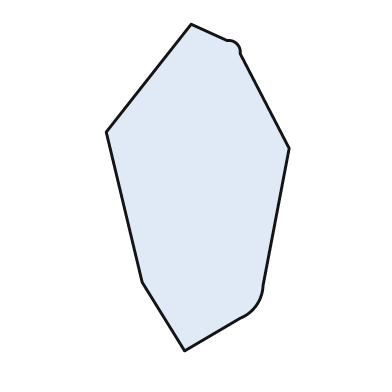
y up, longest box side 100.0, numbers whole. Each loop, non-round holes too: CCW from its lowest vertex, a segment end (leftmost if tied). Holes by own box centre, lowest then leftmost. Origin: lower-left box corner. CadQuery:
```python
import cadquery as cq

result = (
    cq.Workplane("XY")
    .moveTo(24.0, 0.0)
    .lineTo(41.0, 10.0)
    .threePointArc((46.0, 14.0), (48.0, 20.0))
    .lineTo(56.0, 62.0)
    .lineTo(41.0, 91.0)
    .threePointArc((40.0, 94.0), (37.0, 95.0))
    .lineTo(26.0, 100.0)
    .lineTo(0.0, 67.0)
    .lineTo(11.0, 21.0)
    .close()
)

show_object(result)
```